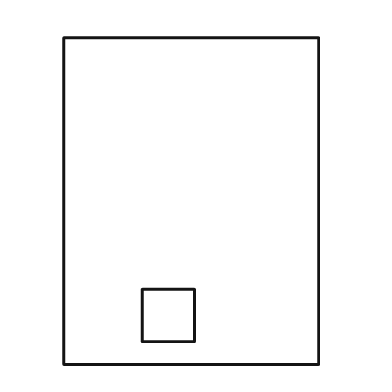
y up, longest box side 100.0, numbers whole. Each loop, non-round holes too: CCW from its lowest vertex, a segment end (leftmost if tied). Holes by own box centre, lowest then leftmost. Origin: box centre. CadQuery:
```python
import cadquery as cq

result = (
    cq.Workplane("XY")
    .moveTo(-39.0, -50.0)
    .lineTo(39.0, -50.0)
    .lineTo(39.0, 50.0)
    .lineTo(-39.0, 50.0)
    .close()
    .moveTo(-15.0, -43.0)
    .lineTo(1.0, -43.0)
    .lineTo(1.0, -27.0)
    .lineTo(-15.0, -27.0)
    .close()
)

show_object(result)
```